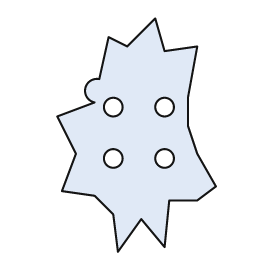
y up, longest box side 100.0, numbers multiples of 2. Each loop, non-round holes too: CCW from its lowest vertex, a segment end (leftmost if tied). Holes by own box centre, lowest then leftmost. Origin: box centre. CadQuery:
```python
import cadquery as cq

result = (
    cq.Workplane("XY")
    .moveTo(-8.0, -50.0)
    .lineTo(2.0, -36.0)
    .lineTo(12.0, -48.0)
    .lineTo(14.0, -28.0)
    .lineTo(26.0, -28.0)
    .lineTo(34.0, -22.0)
    .lineTo(26.0, -8.0)
    .lineTo(22.0, 4.0)
    .lineTo(22.0, 16.0)
    .lineTo(26.0, 38.0)
    .lineTo(12.0, 36.0)
    .lineTo(8.0, 50.0)
    .lineTo(-4.0, 38.0)
    .lineTo(-12.0, 42.0)
    .lineTo(-16.0, 24.0)
    .threePointArc((-22.0, 20.0), (-18.0, 14.0))
    .lineTo(-34.0, 8.0)
    .lineTo(-26.0, -8.0)
    .lineTo(-32.0, -24.0)
    .lineTo(-18.0, -26.0)
    .lineTo(-10.0, -34.0)
    .close()
    .moveTo(-10.0, -10.0)
    .circle(4.0)
    .moveTo(12.0, -10.0)
    .circle(4.0)
    .moveTo(-10.0, 12.0)
    .circle(4.0)
    .moveTo(12.0, 12.0)
    .circle(4.0)
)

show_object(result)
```